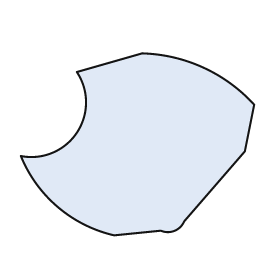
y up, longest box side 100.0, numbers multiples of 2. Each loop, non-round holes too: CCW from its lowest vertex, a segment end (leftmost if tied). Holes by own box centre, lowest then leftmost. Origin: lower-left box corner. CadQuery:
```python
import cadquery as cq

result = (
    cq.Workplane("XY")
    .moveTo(40.0, 0.0)
    .lineTo(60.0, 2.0)
    .threePointArc((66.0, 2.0), (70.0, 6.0))
    .lineTo(96.0, 36.0)
    .lineTo(100.0, 56.0)
    .threePointArc((78.0, 72.0), (52.0, 78.0))
    .lineTo(24.0, 70.0)
    .threePointArc((24.0, 44.0), (0.0, 34.0))
    .threePointArc((16.0, 12.0), (40.0, 0.0))
    .close()
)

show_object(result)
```